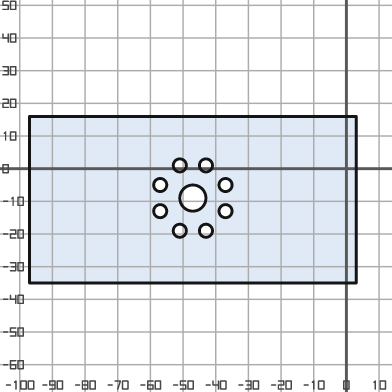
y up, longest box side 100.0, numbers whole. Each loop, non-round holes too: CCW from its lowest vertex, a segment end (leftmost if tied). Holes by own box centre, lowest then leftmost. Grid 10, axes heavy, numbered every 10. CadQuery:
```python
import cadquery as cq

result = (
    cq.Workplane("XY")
    .moveTo(-97.0, -35.0)
    .lineTo(3.0, -35.0)
    .lineTo(3.0, 16.0)
    .lineTo(-97.0, 16.0)
    .close()
    .moveTo(-51.0, -19.0)
    .circle(2.0)
    .moveTo(-43.0, -19.0)
    .circle(2.0)
    .moveTo(-57.0, -13.0)
    .circle(2.0)
    .moveTo(-37.0, -13.0)
    .circle(2.0)
    .moveTo(-47.0, -9.0)
    .circle(4.0)
    .moveTo(-57.0, -5.0)
    .circle(2.0)
    .moveTo(-37.0, -5.0)
    .circle(2.0)
    .moveTo(-51.0, 1.0)
    .circle(2.0)
    .moveTo(-43.0, 1.0)
    .circle(2.0)
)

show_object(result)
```